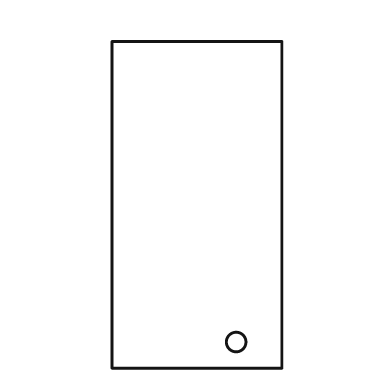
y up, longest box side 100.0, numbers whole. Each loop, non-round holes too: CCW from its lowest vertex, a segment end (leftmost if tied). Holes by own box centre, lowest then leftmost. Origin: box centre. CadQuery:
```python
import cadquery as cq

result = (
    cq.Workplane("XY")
    .moveTo(-26.0, -50.0)
    .lineTo(26.0, -50.0)
    .lineTo(26.0, 50.0)
    .lineTo(-26.0, 50.0)
    .close()
    .moveTo(12.0, -42.0)
    .circle(3.0)
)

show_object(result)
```